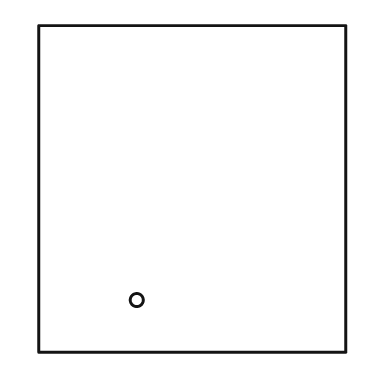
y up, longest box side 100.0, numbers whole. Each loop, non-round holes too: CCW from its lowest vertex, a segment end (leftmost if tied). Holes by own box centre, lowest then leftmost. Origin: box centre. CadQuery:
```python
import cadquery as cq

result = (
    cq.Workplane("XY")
    .moveTo(-47.0, -50.0)
    .lineTo(47.0, -50.0)
    .lineTo(47.0, 50.0)
    .lineTo(-47.0, 50.0)
    .close()
    .moveTo(-17.0, -34.0)
    .circle(2.0)
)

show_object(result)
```